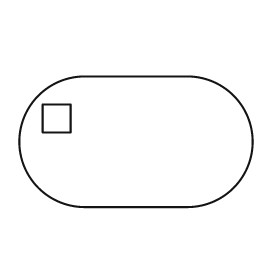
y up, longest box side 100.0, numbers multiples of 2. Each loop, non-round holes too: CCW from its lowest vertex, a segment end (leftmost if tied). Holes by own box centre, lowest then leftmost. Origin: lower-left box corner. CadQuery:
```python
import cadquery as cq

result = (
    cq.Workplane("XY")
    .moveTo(28.0, 0.0)
    .lineTo(72.0, 0.0)
    .threePointArc((100.0, 28.0), (72.0, 56.0))
    .lineTo(28.0, 56.0)
    .threePointArc((0.0, 28.0), (28.0, 0.0))
    .close()
    .moveTo(10.0, 32.0)
    .lineTo(22.0, 32.0)
    .lineTo(22.0, 44.0)
    .lineTo(10.0, 44.0)
    .close()
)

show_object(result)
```